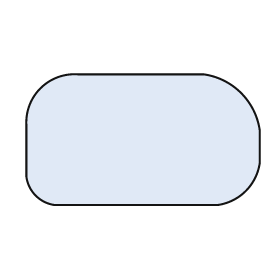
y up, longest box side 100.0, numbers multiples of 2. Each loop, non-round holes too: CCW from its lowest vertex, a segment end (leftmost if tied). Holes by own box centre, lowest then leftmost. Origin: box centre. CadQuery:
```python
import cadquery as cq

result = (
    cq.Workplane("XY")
    .moveTo(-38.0, -28.0)
    .lineTo(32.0, -28.0)
    .threePointArc((44.0, -22.0), (50.0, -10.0))
    .lineTo(50.0, 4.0)
    .threePointArc((42.0, 20.0), (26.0, 28.0))
    .lineTo(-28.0, 28.0)
    .threePointArc((-44.0, 22.0), (-50.0, 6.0))
    .lineTo(-50.0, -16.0)
    .threePointArc((-46.0, -24.0), (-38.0, -28.0))
    .close()
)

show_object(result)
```